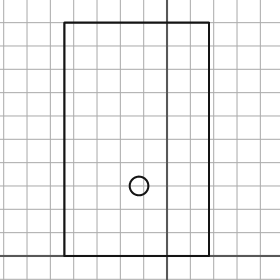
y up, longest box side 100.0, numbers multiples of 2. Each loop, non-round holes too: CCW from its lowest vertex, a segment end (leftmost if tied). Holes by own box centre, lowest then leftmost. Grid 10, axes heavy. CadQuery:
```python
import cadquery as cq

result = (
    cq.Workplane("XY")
    .moveTo(-44.0, 0.0)
    .lineTo(18.0, 0.0)
    .lineTo(18.0, 100.0)
    .lineTo(-44.0, 100.0)
    .close()
    .moveTo(-12.0, 30.0)
    .circle(4.0)
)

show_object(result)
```